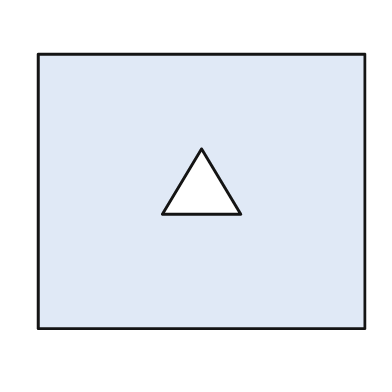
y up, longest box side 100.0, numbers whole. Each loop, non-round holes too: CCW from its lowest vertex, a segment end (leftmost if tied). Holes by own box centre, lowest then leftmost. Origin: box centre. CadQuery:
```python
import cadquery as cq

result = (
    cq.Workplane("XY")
    .moveTo(-50.0, -42.0)
    .lineTo(50.0, -42.0)
    .lineTo(50.0, 42.0)
    .lineTo(-50.0, 42.0)
    .close()
    .moveTo(-12.0, -7.0)
    .lineTo(12.0, -7.0)
    .lineTo(0.0, 13.0)
    .close()
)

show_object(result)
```